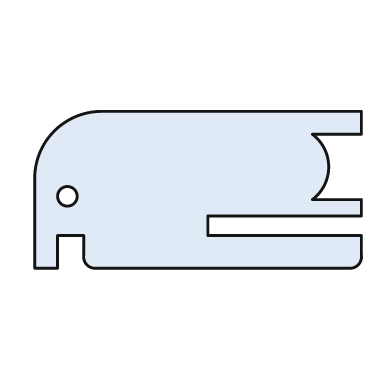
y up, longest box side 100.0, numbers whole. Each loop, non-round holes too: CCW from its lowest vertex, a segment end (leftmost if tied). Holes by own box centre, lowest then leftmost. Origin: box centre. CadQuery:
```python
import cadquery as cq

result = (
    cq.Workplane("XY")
    .moveTo(-50.0, -24.0)
    .lineTo(-43.0, -24.0)
    .lineTo(-43.0, -14.0)
    .lineTo(-35.0, -14.0)
    .lineTo(-35.0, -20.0)
    .threePointArc((-34.0, -23.0), (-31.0, -24.0))
    .lineTo(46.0, -24.0)
    .threePointArc((49.0, -23.0), (50.0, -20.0))
    .lineTo(50.0, -14.0)
    .lineTo(3.0, -14.0)
    .lineTo(3.0, -8.0)
    .lineTo(50.0, -8.0)
    .lineTo(50.0, -3.0)
    .lineTo(35.0, -3.0)
    .threePointArc((40.0, 7.0), (35.0, 17.0))
    .lineTo(50.0, 17.0)
    .lineTo(50.0, 24.0)
    .lineTo(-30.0, 24.0)
    .threePointArc((-44.0, 18.0), (-50.0, 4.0))
    .close()
    .moveTo(-40.0, -2.0)
    .circle(3.0)
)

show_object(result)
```